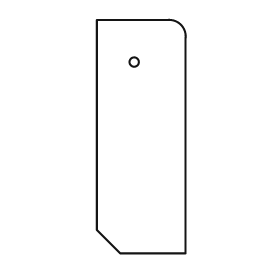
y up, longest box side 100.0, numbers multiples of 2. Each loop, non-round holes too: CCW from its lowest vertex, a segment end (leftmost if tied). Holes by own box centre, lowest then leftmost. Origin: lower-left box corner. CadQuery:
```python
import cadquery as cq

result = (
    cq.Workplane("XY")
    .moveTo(10.0, 0.0)
    .lineTo(38.0, 0.0)
    .lineTo(38.0, 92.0)
    .threePointArc((36.0, 98.0), (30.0, 100.0))
    .lineTo(0.0, 100.0)
    .lineTo(0.0, 10.0)
    .close()
    .moveTo(16.0, 82.0)
    .circle(2.0)
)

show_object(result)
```